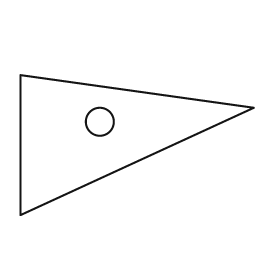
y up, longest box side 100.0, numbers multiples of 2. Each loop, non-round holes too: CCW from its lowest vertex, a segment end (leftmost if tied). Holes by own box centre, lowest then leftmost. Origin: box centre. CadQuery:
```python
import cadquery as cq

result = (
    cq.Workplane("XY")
    .moveTo(-50.0, -30.0)
    .lineTo(50.0, 16.0)
    .lineTo(-50.0, 30.0)
    .close()
    .moveTo(-16.0, 10.0)
    .circle(6.0)
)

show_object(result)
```